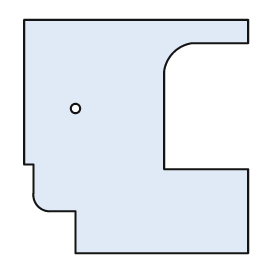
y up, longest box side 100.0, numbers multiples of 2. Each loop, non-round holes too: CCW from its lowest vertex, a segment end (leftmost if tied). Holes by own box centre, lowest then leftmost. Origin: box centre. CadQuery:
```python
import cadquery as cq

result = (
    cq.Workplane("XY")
    .moveTo(-26.0, -50.0)
    .lineTo(48.0, -50.0)
    .lineTo(48.0, -14.0)
    .lineTo(12.0, -14.0)
    .lineTo(12.0, 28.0)
    .threePointArc((16.0, 36.0), (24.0, 40.0))
    .lineTo(48.0, 40.0)
    .lineTo(48.0, 50.0)
    .lineTo(-48.0, 50.0)
    .lineTo(-48.0, -12.0)
    .lineTo(-44.0, -12.0)
    .lineTo(-44.0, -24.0)
    .threePointArc((-42.0, -30.0), (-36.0, -32.0))
    .lineTo(-26.0, -32.0)
    .close()
    .moveTo(-26.0, 12.0)
    .circle(2.0)
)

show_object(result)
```